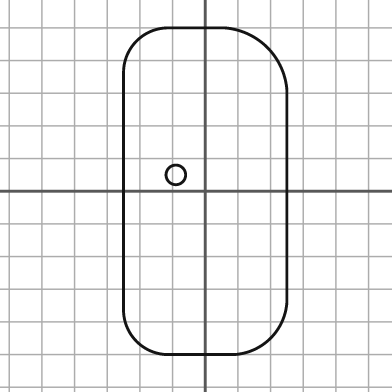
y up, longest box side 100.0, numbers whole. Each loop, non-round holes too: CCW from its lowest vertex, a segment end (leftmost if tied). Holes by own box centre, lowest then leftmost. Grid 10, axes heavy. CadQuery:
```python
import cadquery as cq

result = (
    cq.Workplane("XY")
    .moveTo(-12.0, -50.0)
    .lineTo(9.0, -50.0)
    .threePointArc((20.0, -45.0), (25.0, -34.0))
    .lineTo(25.0, 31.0)
    .threePointArc((19.0, 44.0), (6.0, 50.0))
    .lineTo(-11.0, 50.0)
    .threePointArc((-21.0, 46.0), (-25.0, 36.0))
    .lineTo(-25.0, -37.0)
    .threePointArc((-21.0, -46.0), (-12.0, -50.0))
    .close()
    .moveTo(-9.0, 5.0)
    .circle(3.0)
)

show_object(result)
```